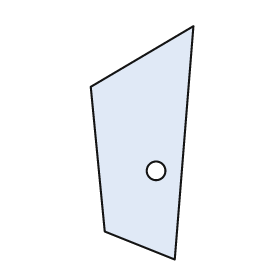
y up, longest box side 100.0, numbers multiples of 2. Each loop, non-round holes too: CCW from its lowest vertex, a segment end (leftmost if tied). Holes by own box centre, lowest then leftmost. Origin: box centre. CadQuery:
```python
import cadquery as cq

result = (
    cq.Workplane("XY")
    .moveTo(14.0, -50.0)
    .lineTo(22.0, 50.0)
    .lineTo(-22.0, 24.0)
    .lineTo(-16.0, -38.0)
    .close()
    .moveTo(6.0, -12.0)
    .circle(4.0)
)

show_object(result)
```